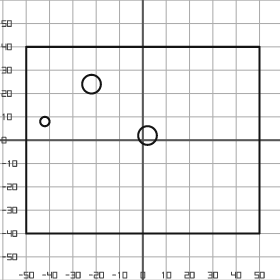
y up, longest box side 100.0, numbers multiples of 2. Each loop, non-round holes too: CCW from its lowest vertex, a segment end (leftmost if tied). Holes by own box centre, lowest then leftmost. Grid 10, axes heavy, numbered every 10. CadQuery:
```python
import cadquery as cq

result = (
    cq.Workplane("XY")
    .moveTo(-50.0, -40.0)
    .lineTo(50.0, -40.0)
    .lineTo(50.0, 40.0)
    .lineTo(-50.0, 40.0)
    .close()
    .moveTo(2.0, 2.0)
    .circle(4.0)
    .moveTo(-42.0, 8.0)
    .circle(2.0)
    .moveTo(-22.0, 24.0)
    .circle(4.0)
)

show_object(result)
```